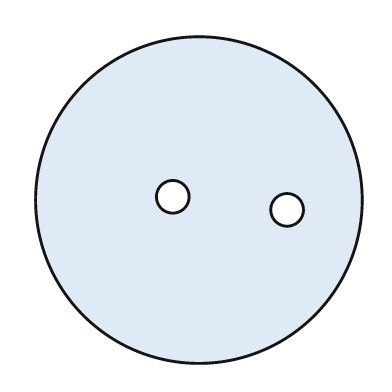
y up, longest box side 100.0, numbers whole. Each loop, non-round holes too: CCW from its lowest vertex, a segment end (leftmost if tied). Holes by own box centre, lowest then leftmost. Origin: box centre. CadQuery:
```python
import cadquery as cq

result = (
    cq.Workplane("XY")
    .moveTo(0.0, 0.0)
    .circle(50.0)
    .moveTo(27.0, -3.0)
    .circle(5.0)
    .moveTo(-8.0, 1.0)
    .circle(5.0)
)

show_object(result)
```